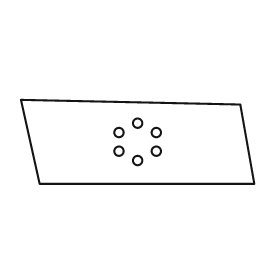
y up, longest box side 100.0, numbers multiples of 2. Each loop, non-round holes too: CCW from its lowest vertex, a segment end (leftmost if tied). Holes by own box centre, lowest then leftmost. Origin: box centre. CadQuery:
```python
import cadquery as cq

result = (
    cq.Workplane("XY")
    .moveTo(-42.0, -18.0)
    .lineTo(50.0, -18.0)
    .lineTo(44.0, 16.0)
    .lineTo(-50.0, 18.0)
    .close()
    .moveTo(0.0, -8.0)
    .circle(2.0)
    .moveTo(-8.0, -4.0)
    .circle(2.0)
    .moveTo(8.0, -4.0)
    .circle(2.0)
    .moveTo(-8.0, 4.0)
    .circle(2.0)
    .moveTo(8.0, 4.0)
    .circle(2.0)
    .moveTo(0.0, 8.0)
    .circle(2.0)
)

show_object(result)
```